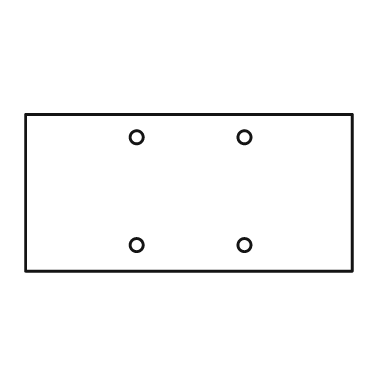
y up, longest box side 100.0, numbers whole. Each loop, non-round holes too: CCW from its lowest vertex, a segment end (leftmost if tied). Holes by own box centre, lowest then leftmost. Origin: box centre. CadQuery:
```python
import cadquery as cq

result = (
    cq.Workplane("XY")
    .moveTo(-50.0, -24.0)
    .lineTo(50.0, -24.0)
    .lineTo(50.0, 24.0)
    .lineTo(-50.0, 24.0)
    .close()
    .moveTo(-16.0, -16.0)
    .circle(2.0)
    .moveTo(17.0, -16.0)
    .circle(2.0)
    .moveTo(-16.0, 17.0)
    .circle(2.0)
    .moveTo(17.0, 17.0)
    .circle(2.0)
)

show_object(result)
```